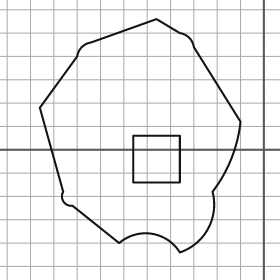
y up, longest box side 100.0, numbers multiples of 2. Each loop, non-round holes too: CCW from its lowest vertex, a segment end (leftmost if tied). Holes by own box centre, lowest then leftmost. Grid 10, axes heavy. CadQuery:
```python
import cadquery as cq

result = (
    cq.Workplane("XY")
    .moveTo(-36.0, -44.0)
    .threePointArc((-24.0, -34.0), (-22.0, -18.0))
    .threePointArc((-14.0, -4.0), (-10.0, 12.0))
    .lineTo(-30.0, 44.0)
    .threePointArc((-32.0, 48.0), (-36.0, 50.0))
    .lineTo(-46.0, 56.0)
    .lineTo(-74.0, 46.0)
    .threePointArc((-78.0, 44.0), (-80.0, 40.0))
    .lineTo(-96.0, 18.0)
    .lineTo(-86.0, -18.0)
    .threePointArc((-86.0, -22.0), (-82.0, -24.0))
    .lineTo(-62.0, -40.0)
    .threePointArc((-48.0, -36.0), (-36.0, -44.0))
    .close()
    .moveTo(-56.0, -14.0)
    .lineTo(-36.0, -14.0)
    .lineTo(-36.0, 6.0)
    .lineTo(-56.0, 6.0)
    .close()
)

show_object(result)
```